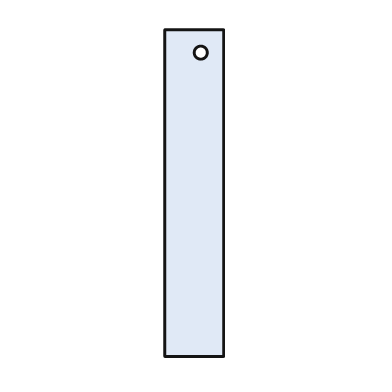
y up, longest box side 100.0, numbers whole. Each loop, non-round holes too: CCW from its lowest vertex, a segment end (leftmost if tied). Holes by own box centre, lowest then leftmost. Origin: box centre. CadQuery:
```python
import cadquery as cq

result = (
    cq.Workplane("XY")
    .moveTo(-9.0, -50.0)
    .lineTo(9.0, -50.0)
    .lineTo(9.0, 50.0)
    .lineTo(-9.0, 50.0)
    .close()
    .moveTo(2.0, 43.0)
    .circle(2.0)
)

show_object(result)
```